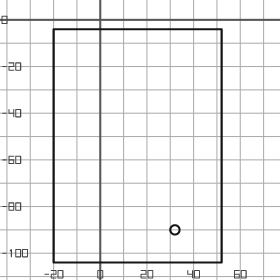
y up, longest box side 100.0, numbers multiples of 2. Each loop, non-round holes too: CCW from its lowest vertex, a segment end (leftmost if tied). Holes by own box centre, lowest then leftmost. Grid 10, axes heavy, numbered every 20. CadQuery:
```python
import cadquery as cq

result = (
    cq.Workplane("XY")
    .moveTo(-20.0, -104.0)
    .lineTo(52.0, -104.0)
    .lineTo(52.0, -4.0)
    .lineTo(-20.0, -4.0)
    .close()
    .moveTo(32.0, -90.0)
    .circle(2.0)
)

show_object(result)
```